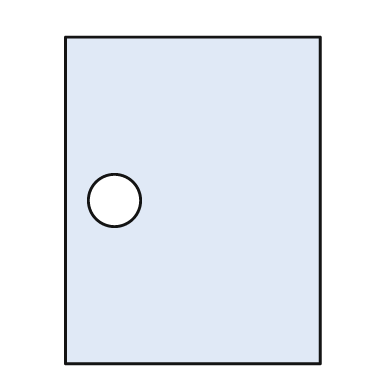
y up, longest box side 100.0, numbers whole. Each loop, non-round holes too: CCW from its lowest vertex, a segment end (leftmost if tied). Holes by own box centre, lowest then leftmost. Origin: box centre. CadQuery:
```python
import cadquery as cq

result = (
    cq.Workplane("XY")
    .moveTo(-39.0, -50.0)
    .lineTo(39.0, -50.0)
    .lineTo(39.0, 50.0)
    .lineTo(-39.0, 50.0)
    .close()
    .moveTo(-24.0, 0.0)
    .circle(8.0)
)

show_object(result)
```